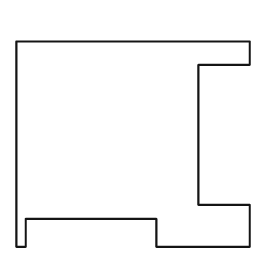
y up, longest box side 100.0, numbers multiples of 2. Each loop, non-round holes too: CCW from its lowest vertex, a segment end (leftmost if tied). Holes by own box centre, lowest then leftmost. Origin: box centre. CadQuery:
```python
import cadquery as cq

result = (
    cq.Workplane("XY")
    .moveTo(-50.0, -44.0)
    .lineTo(-46.0, -44.0)
    .lineTo(-46.0, -32.0)
    .lineTo(10.0, -32.0)
    .lineTo(10.0, -44.0)
    .lineTo(50.0, -44.0)
    .lineTo(50.0, -26.0)
    .lineTo(28.0, -26.0)
    .lineTo(28.0, 34.0)
    .lineTo(50.0, 34.0)
    .lineTo(50.0, 44.0)
    .lineTo(-50.0, 44.0)
    .close()
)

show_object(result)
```